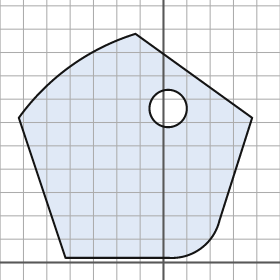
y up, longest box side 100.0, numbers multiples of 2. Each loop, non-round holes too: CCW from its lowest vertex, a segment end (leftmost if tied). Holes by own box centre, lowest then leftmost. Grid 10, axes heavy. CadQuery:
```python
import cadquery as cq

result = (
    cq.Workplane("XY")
    .moveTo(-42.0, 2.0)
    .lineTo(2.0, 2.0)
    .threePointArc((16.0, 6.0), (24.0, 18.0))
    .lineTo(38.0, 62.0)
    .lineTo(-12.0, 98.0)
    .threePointArc((-40.0, 84.0), (-62.0, 62.0))
    .close()
    .moveTo(2.0, 66.0)
    .circle(8.0)
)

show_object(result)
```